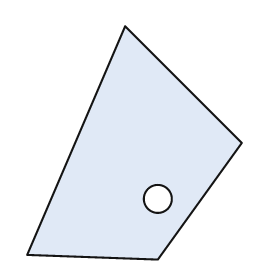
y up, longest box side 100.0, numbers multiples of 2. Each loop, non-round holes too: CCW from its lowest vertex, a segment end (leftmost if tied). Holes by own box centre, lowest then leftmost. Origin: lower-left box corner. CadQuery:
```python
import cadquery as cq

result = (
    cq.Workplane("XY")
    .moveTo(56.0, 0.0)
    .lineTo(92.0, 50.0)
    .lineTo(42.0, 100.0)
    .lineTo(0.0, 2.0)
    .close()
    .moveTo(56.0, 26.0)
    .circle(6.0)
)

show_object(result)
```